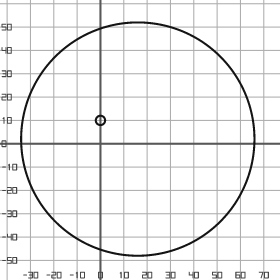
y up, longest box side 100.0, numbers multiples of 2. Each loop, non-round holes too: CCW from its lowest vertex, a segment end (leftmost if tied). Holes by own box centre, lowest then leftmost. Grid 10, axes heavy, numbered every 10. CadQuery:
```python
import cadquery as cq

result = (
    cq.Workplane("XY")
    .moveTo(16.0, 2.0)
    .circle(50.0)
    .moveTo(0.0, 10.0)
    .circle(2.0)
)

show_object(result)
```